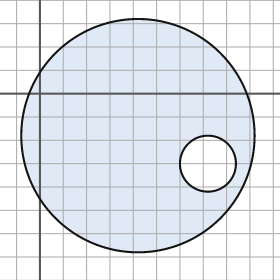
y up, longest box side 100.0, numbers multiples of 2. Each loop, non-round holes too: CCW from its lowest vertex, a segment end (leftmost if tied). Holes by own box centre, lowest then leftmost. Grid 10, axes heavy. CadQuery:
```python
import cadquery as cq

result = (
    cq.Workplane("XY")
    .moveTo(42.0, -18.0)
    .circle(50.0)
    .moveTo(72.0, -30.0)
    .circle(12.0)
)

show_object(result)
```